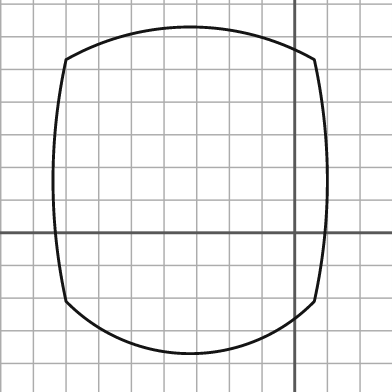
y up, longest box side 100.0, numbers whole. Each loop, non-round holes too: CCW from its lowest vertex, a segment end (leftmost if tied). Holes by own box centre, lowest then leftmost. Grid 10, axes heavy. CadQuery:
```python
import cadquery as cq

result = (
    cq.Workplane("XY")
    .moveTo(-70.0, -21.0)
    .threePointArc((-32.0, -37.0), (6.0, -21.0))
    .threePointArc((10.0, 16.0), (6.0, 53.0))
    .threePointArc((-32.0, 63.0), (-70.0, 53.0))
    .threePointArc((-74.0, 16.0), (-70.0, -21.0))
    .close()
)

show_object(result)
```